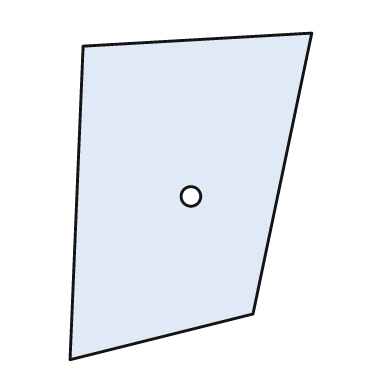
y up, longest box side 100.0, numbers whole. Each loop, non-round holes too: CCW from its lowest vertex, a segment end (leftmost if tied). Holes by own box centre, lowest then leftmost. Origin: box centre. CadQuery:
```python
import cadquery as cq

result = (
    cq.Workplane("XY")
    .moveTo(-37.0, -50.0)
    .lineTo(19.0, -36.0)
    .lineTo(37.0, 50.0)
    .lineTo(-33.0, 46.0)
    .close()
    .moveTo(0.0, 0.0)
    .circle(3.0)
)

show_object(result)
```